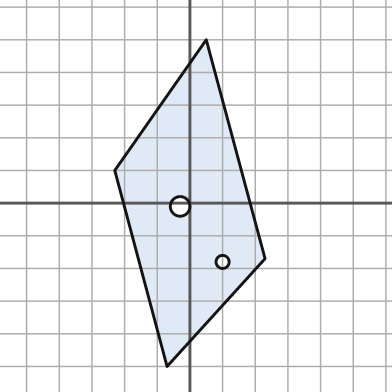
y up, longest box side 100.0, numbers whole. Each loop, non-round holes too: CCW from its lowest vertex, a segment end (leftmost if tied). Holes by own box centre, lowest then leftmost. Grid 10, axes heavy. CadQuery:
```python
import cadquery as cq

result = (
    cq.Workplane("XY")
    .moveTo(-7.0, -50.0)
    .lineTo(23.0, -17.0)
    .lineTo(5.0, 50.0)
    .lineTo(-23.0, 10.0)
    .close()
    .moveTo(10.0, -18.0)
    .circle(2.0)
    .moveTo(-3.0, -1.0)
    .circle(3.0)
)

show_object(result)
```